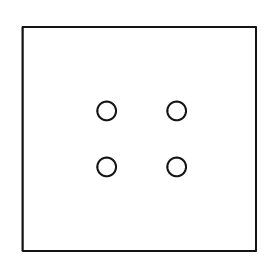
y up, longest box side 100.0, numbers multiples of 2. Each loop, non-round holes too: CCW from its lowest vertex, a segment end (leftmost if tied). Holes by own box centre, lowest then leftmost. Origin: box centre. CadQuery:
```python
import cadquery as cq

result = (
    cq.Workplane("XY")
    .moveTo(-50.0, -48.0)
    .lineTo(50.0, -48.0)
    .lineTo(50.0, 48.0)
    .lineTo(-50.0, 48.0)
    .close()
    .moveTo(-14.0, -12.0)
    .circle(4.0)
    .moveTo(16.0, -12.0)
    .circle(4.0)
    .moveTo(-14.0, 12.0)
    .circle(4.0)
    .moveTo(16.0, 12.0)
    .circle(4.0)
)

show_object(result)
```